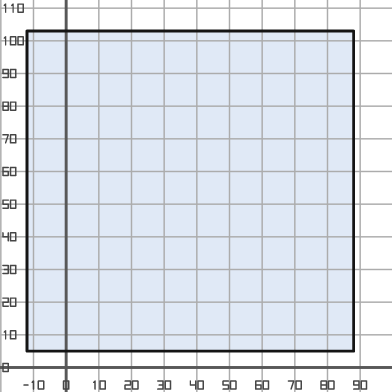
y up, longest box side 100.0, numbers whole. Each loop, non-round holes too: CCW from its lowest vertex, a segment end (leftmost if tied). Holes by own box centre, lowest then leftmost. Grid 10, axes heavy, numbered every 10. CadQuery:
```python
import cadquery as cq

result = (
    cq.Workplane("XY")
    .moveTo(-12.0, 5.0)
    .lineTo(88.0, 5.0)
    .lineTo(88.0, 103.0)
    .lineTo(-12.0, 103.0)
    .close()
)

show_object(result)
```